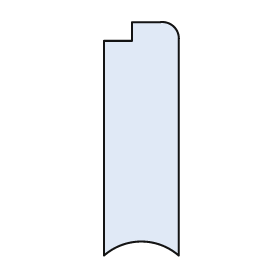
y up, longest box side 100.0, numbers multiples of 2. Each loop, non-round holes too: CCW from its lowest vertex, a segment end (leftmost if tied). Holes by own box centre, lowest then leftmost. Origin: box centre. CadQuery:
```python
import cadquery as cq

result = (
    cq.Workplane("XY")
    .moveTo(-16.0, -50.0)
    .threePointArc((0.0, -44.0), (16.0, -50.0))
    .lineTo(16.0, 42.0)
    .threePointArc((14.0, 48.0), (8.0, 50.0))
    .lineTo(-4.0, 50.0)
    .lineTo(-4.0, 42.0)
    .lineTo(-16.0, 42.0)
    .close()
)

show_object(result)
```